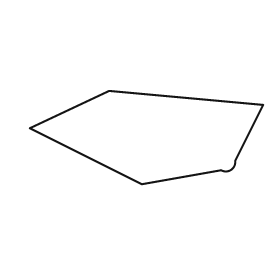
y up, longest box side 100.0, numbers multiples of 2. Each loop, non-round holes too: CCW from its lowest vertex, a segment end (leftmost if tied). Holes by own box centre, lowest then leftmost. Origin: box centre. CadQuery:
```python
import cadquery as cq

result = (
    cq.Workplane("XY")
    .moveTo(-2.0, -20.0)
    .lineTo(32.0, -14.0)
    .threePointArc((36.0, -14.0), (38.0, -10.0))
    .lineTo(50.0, 14.0)
    .lineTo(-16.0, 20.0)
    .lineTo(-50.0, 4.0)
    .close()
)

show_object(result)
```